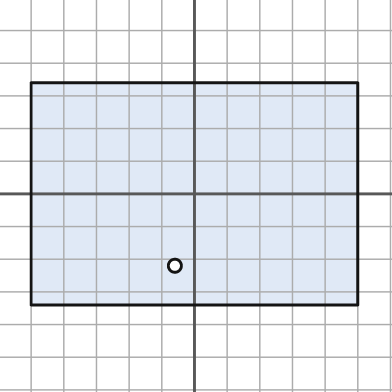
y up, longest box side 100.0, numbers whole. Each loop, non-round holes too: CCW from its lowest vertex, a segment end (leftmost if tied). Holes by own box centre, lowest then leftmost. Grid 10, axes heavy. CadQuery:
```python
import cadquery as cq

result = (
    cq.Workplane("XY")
    .moveTo(-50.0, -34.0)
    .lineTo(50.0, -34.0)
    .lineTo(50.0, 34.0)
    .lineTo(-50.0, 34.0)
    .close()
    .moveTo(-6.0, -22.0)
    .circle(2.0)
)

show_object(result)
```